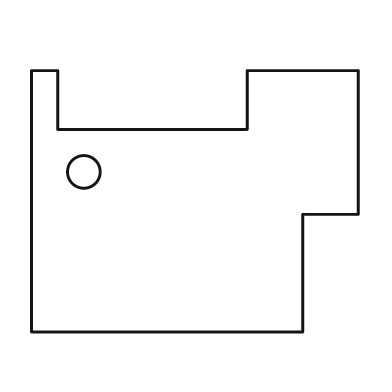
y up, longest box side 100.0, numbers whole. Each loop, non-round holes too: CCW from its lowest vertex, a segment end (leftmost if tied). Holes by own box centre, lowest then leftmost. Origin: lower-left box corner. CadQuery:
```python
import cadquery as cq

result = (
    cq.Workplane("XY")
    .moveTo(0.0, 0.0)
    .lineTo(83.0, 0.0)
    .lineTo(83.0, 36.0)
    .lineTo(100.0, 36.0)
    .lineTo(100.0, 80.0)
    .lineTo(66.0, 80.0)
    .lineTo(66.0, 62.0)
    .lineTo(8.0, 62.0)
    .lineTo(8.0, 80.0)
    .lineTo(0.0, 80.0)
    .close()
    .moveTo(16.0, 49.0)
    .circle(5.0)
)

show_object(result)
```